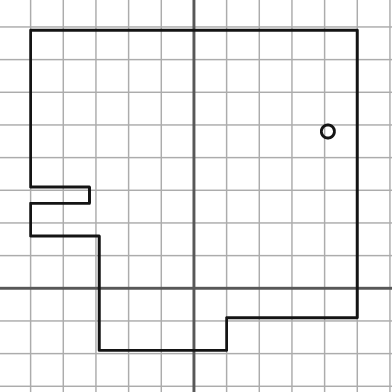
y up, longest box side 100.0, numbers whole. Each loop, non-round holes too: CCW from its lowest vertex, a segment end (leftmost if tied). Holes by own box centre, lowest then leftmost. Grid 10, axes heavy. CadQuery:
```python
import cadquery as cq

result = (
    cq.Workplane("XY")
    .moveTo(-29.0, -19.0)
    .lineTo(10.0, -19.0)
    .lineTo(10.0, -9.0)
    .lineTo(50.0, -9.0)
    .lineTo(50.0, 79.0)
    .lineTo(-50.0, 79.0)
    .lineTo(-50.0, 31.0)
    .lineTo(-32.0, 31.0)
    .lineTo(-32.0, 26.0)
    .lineTo(-50.0, 26.0)
    .lineTo(-50.0, 16.0)
    .lineTo(-29.0, 16.0)
    .close()
    .moveTo(41.0, 48.0)
    .circle(2.0)
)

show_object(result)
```